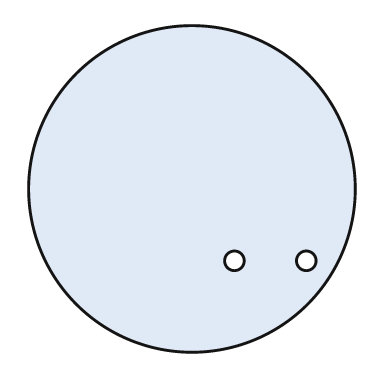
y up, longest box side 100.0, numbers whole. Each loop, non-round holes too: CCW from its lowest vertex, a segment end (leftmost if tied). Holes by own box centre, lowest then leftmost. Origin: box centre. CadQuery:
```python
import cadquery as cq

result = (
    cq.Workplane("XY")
    .moveTo(0.0, 0.0)
    .circle(50.0)
    .moveTo(13.0, -22.0)
    .circle(3.0)
    .moveTo(35.0, -22.0)
    .circle(3.0)
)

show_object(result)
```